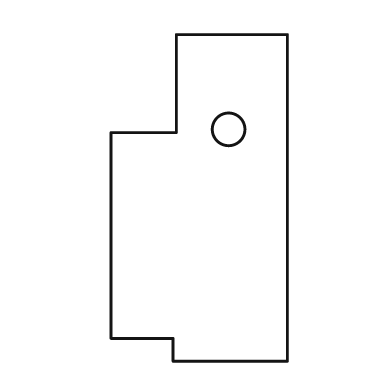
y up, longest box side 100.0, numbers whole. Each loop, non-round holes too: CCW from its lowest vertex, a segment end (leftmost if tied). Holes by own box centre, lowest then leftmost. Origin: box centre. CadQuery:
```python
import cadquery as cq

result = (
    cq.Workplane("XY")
    .moveTo(-8.0, -50.0)
    .lineTo(27.0, -50.0)
    .lineTo(27.0, 50.0)
    .lineTo(-7.0, 50.0)
    .lineTo(-7.0, 20.0)
    .lineTo(-27.0, 20.0)
    .lineTo(-27.0, -43.0)
    .lineTo(-8.0, -43.0)
    .close()
    .moveTo(9.0, 21.0)
    .circle(5.0)
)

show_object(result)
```